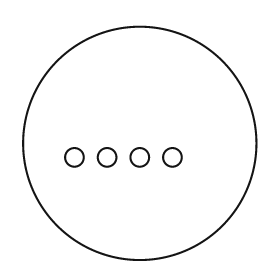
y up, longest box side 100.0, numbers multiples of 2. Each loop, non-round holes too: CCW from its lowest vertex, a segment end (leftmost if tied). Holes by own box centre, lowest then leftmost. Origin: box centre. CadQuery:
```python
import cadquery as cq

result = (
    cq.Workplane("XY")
    .moveTo(0.0, 0.0)
    .circle(50.0)
    .moveTo(-28.0, -6.0)
    .circle(4.0)
    .moveTo(-14.0, -6.0)
    .circle(4.0)
    .moveTo(0.0, -6.0)
    .circle(4.0)
    .moveTo(14.0, -6.0)
    .circle(4.0)
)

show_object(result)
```